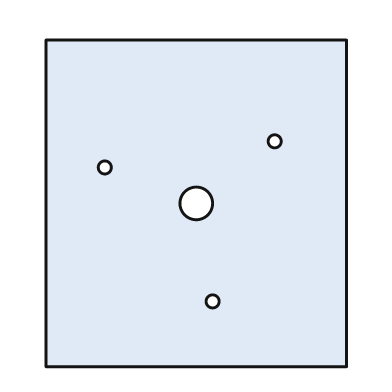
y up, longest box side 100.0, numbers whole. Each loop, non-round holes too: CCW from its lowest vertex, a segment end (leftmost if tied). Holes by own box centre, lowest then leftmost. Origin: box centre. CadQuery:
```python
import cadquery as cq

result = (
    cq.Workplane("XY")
    .moveTo(-46.0, -50.0)
    .lineTo(46.0, -50.0)
    .lineTo(46.0, 50.0)
    .lineTo(-46.0, 50.0)
    .close()
    .moveTo(5.0, -30.0)
    .circle(2.0)
    .moveTo(0.0, 0.0)
    .circle(5.0)
    .moveTo(-28.0, 11.0)
    .circle(2.0)
    .moveTo(24.0, 19.0)
    .circle(2.0)
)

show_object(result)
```